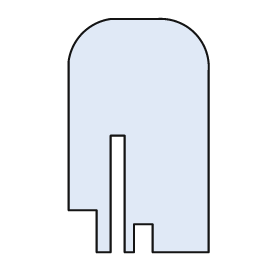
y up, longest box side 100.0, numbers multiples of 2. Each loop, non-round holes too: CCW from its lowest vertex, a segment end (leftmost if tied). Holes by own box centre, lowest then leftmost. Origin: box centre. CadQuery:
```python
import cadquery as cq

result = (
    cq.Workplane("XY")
    .moveTo(-18.0, -50.0)
    .lineTo(-12.0, -50.0)
    .lineTo(-12.0, 0.0)
    .lineTo(-6.0, 0.0)
    .lineTo(-6.0, -50.0)
    .lineTo(-2.0, -50.0)
    .lineTo(-2.0, -38.0)
    .lineTo(6.0, -38.0)
    .lineTo(6.0, -50.0)
    .lineTo(30.0, -50.0)
    .lineTo(30.0, 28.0)
    .threePointArc((24.0, 44.0), (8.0, 50.0))
    .lineTo(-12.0, 50.0)
    .threePointArc((-24.0, 44.0), (-30.0, 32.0))
    .lineTo(-30.0, -32.0)
    .lineTo(-18.0, -32.0)
    .close()
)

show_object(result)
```